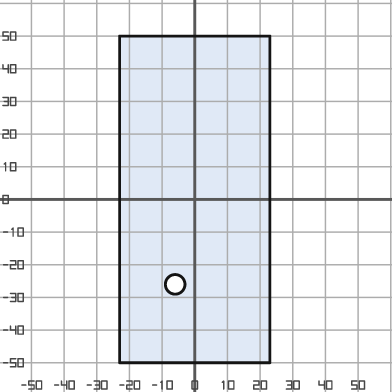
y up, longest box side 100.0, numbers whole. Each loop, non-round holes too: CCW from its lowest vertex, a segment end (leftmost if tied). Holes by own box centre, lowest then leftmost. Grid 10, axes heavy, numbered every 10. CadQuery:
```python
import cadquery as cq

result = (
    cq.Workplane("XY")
    .moveTo(-23.0, -50.0)
    .lineTo(23.0, -50.0)
    .lineTo(23.0, 50.0)
    .lineTo(-23.0, 50.0)
    .close()
    .moveTo(-6.0, -26.0)
    .circle(3.0)
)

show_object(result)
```